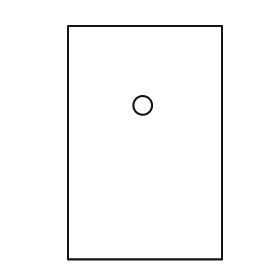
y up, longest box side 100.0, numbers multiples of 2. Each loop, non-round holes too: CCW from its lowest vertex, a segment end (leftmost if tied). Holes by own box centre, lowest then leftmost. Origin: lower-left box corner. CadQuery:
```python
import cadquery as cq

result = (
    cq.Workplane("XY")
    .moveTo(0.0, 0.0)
    .lineTo(66.0, 0.0)
    .lineTo(66.0, 100.0)
    .lineTo(0.0, 100.0)
    .close()
    .moveTo(32.0, 66.0)
    .circle(4.0)
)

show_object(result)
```